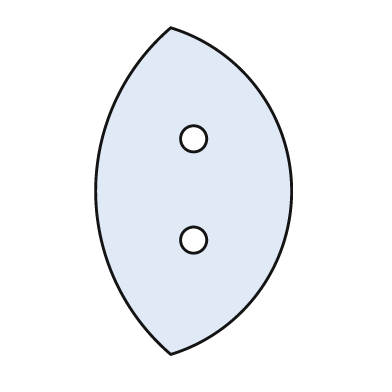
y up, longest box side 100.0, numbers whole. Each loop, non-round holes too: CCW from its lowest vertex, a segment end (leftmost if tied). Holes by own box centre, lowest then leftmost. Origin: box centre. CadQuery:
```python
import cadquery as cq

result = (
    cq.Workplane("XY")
    .moveTo(-7.0, -50.0)
    .threePointArc((30.0, 0.0), (-7.0, 50.0))
    .threePointArc((-30.0, 0.0), (-7.0, -50.0))
    .close()
    .moveTo(0.0, -15.0)
    .circle(4.0)
    .moveTo(0.0, 16.0)
    .circle(4.0)
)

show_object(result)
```